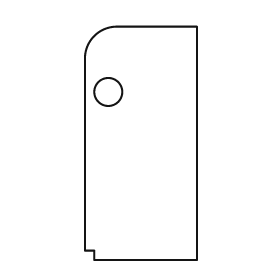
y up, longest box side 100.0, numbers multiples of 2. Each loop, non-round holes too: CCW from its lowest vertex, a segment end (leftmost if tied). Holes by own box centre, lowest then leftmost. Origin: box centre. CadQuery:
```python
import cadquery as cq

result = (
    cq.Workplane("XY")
    .moveTo(-20.0, -50.0)
    .lineTo(24.0, -50.0)
    .lineTo(24.0, 50.0)
    .lineTo(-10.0, 50.0)
    .threePointArc((-20.0, 46.0), (-24.0, 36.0))
    .lineTo(-24.0, -46.0)
    .lineTo(-20.0, -46.0)
    .close()
    .moveTo(-14.0, 22.0)
    .circle(6.0)
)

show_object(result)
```